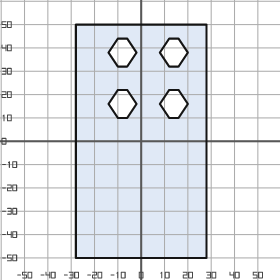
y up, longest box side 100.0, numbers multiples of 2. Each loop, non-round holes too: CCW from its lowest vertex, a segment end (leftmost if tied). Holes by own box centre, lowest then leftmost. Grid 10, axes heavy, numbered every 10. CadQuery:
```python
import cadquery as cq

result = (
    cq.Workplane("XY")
    .moveTo(-28.0, -50.0)
    .lineTo(28.0, -50.0)
    .lineTo(28.0, 50.0)
    .lineTo(-28.0, 50.0)
    .close()
    .moveTo(-10.0, 10.0)
    .lineTo(-6.0, 10.0)
    .lineTo(-2.0, 16.0)
    .lineTo(-6.0, 22.0)
    .lineTo(-10.0, 22.0)
    .lineTo(-14.0, 16.0)
    .close()
    .moveTo(12.0, 10.0)
    .lineTo(16.0, 10.0)
    .lineTo(20.0, 16.0)
    .lineTo(16.0, 22.0)
    .lineTo(12.0, 22.0)
    .lineTo(8.0, 16.0)
    .close()
    .moveTo(-10.0, 32.0)
    .lineTo(-6.0, 32.0)
    .lineTo(-2.0, 38.0)
    .lineTo(-6.0, 44.0)
    .lineTo(-10.0, 44.0)
    .lineTo(-14.0, 38.0)
    .close()
    .moveTo(12.0, 32.0)
    .lineTo(16.0, 32.0)
    .lineTo(20.0, 38.0)
    .lineTo(16.0, 44.0)
    .lineTo(12.0, 44.0)
    .lineTo(8.0, 38.0)
    .close()
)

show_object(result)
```